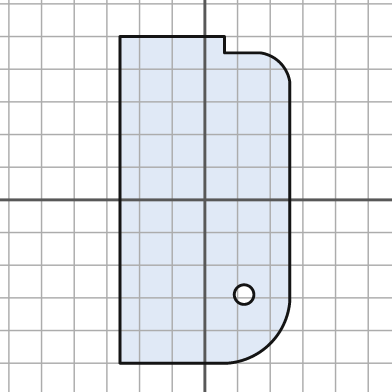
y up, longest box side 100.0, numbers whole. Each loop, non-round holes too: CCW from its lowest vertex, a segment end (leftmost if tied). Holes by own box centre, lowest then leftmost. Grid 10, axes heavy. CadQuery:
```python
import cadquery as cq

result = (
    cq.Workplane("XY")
    .moveTo(-26.0, -50.0)
    .lineTo(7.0, -50.0)
    .threePointArc((20.0, -44.0), (26.0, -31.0))
    .lineTo(26.0, 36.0)
    .threePointArc((23.0, 42.0), (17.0, 45.0))
    .lineTo(6.0, 45.0)
    .lineTo(6.0, 50.0)
    .lineTo(-26.0, 50.0)
    .close()
    .moveTo(12.0, -29.0)
    .circle(3.0)
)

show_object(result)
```